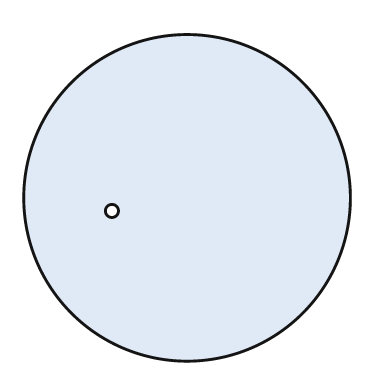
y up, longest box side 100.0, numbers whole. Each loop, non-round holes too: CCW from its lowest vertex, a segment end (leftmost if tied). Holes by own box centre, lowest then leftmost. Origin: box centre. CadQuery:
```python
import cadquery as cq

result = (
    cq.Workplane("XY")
    .moveTo(0.0, 0.0)
    .circle(50.0)
    .moveTo(-23.0, -4.0)
    .circle(2.0)
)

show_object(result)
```